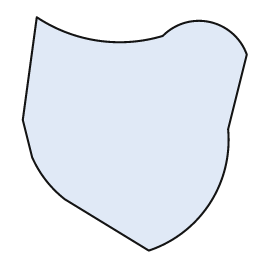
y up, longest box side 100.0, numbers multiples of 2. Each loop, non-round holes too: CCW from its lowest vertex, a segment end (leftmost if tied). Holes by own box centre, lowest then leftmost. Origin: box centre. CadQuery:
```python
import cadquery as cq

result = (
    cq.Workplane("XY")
    .moveTo(6.0, -50.0)
    .threePointArc((32.0, -30.0), (40.0, 2.0))
    .lineTo(48.0, 34.0)
    .threePointArc((32.0, 48.0), (12.0, 42.0))
    .threePointArc((-16.0, 40.0), (-42.0, 50.0))
    .lineTo(-48.0, 6.0)
    .lineTo(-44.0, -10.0)
    .threePointArc((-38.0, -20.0), (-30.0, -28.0))
    .close()
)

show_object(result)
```